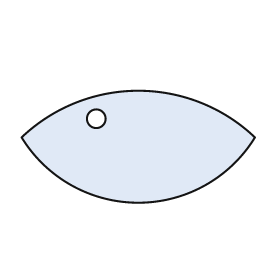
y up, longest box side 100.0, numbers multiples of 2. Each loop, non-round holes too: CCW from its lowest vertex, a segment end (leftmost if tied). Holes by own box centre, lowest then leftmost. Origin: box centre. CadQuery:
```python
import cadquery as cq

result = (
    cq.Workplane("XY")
    .moveTo(-50.0, 4.0)
    .threePointArc((0.0, -24.0), (50.0, 4.0))
    .threePointArc((0.0, 24.0), (-50.0, 4.0))
    .close()
    .moveTo(-18.0, 12.0)
    .circle(4.0)
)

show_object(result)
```